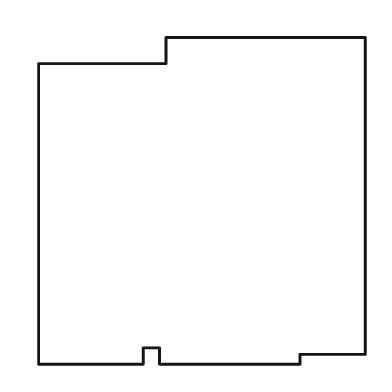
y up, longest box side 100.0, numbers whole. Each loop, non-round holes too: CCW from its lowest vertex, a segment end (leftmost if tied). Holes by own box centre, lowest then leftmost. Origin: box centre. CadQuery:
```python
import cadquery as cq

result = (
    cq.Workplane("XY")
    .moveTo(-50.0, -50.0)
    .lineTo(-18.0, -50.0)
    .lineTo(-18.0, -45.0)
    .lineTo(-13.0, -45.0)
    .lineTo(-13.0, -50.0)
    .lineTo(30.0, -50.0)
    .lineTo(30.0, -47.0)
    .lineTo(50.0, -47.0)
    .lineTo(50.0, 50.0)
    .lineTo(-11.0, 50.0)
    .lineTo(-11.0, 42.0)
    .lineTo(-50.0, 42.0)
    .close()
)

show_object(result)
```